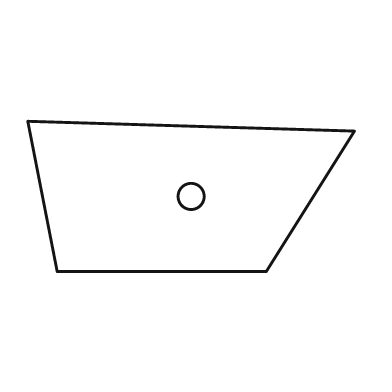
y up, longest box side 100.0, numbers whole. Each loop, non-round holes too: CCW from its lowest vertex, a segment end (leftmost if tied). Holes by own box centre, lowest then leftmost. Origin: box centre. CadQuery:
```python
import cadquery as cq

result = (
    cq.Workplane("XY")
    .moveTo(-41.0, -23.0)
    .lineTo(23.0, -23.0)
    .lineTo(50.0, 20.0)
    .lineTo(-50.0, 23.0)
    .close()
    .moveTo(0.0, 0.0)
    .circle(4.0)
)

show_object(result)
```